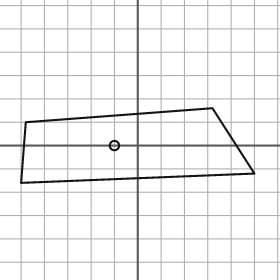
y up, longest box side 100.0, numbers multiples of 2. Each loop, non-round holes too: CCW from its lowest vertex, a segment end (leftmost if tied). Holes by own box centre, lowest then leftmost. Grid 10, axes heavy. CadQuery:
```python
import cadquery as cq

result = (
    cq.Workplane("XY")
    .moveTo(-50.0, -16.0)
    .lineTo(50.0, -12.0)
    .lineTo(32.0, 16.0)
    .lineTo(-48.0, 10.0)
    .close()
    .moveTo(-10.0, 0.0)
    .circle(2.0)
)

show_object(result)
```